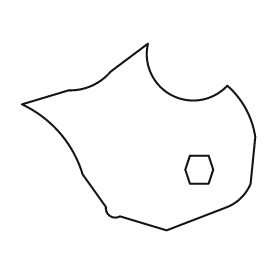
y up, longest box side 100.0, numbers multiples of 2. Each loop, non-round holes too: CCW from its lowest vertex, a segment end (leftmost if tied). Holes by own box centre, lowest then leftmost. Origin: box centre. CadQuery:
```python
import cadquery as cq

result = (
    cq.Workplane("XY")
    .moveTo(12.0, -40.0)
    .lineTo(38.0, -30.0)
    .threePointArc((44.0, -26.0), (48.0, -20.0))
    .lineTo(50.0, 0.0)
    .threePointArc((46.0, 12.0), (38.0, 22.0))
    .threePointArc((14.0, 18.0), (4.0, 40.0))
    .lineTo(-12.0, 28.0)
    .threePointArc((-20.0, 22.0), (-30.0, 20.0))
    .lineTo(-50.0, 14.0)
    .threePointArc((-34.0, 2.0), (-24.0, -16.0))
    .lineTo(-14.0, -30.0)
    .threePointArc((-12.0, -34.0), (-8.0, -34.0))
    .close()
    .moveTo(22.0, -20.0)
    .lineTo(30.0, -20.0)
    .lineTo(32.0, -14.0)
    .lineTo(30.0, -8.0)
    .lineTo(22.0, -8.0)
    .lineTo(20.0, -14.0)
    .close()
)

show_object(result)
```